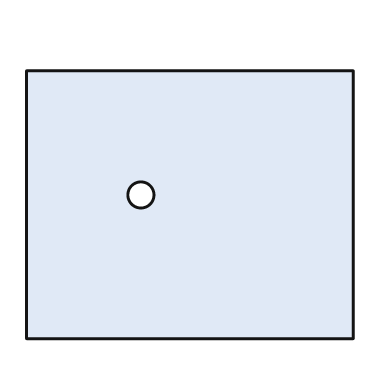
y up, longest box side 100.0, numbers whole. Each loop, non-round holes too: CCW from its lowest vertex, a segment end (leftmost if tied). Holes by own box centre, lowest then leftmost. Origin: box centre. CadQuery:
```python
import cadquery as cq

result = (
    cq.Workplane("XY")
    .moveTo(-50.0, -41.0)
    .lineTo(50.0, -41.0)
    .lineTo(50.0, 41.0)
    .lineTo(-50.0, 41.0)
    .close()
    .moveTo(-15.0, 3.0)
    .circle(4.0)
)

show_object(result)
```